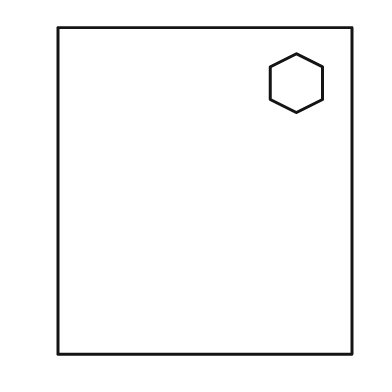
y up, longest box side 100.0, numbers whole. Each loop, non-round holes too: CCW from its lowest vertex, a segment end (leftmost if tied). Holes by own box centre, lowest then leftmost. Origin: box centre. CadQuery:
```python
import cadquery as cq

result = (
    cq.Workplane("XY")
    .moveTo(-45.0, -50.0)
    .lineTo(45.0, -50.0)
    .lineTo(45.0, 50.0)
    .lineTo(-45.0, 50.0)
    .close()
    .moveTo(28.0, 24.0)
    .lineTo(36.0, 28.0)
    .lineTo(36.0, 38.0)
    .lineTo(28.0, 42.0)
    .lineTo(20.0, 38.0)
    .lineTo(20.0, 28.0)
    .close()
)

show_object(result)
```